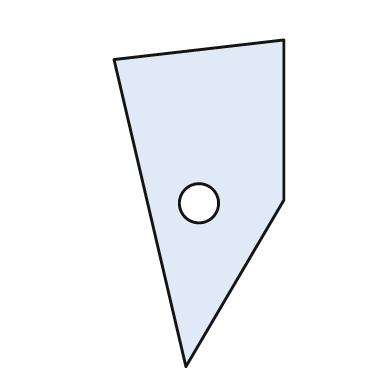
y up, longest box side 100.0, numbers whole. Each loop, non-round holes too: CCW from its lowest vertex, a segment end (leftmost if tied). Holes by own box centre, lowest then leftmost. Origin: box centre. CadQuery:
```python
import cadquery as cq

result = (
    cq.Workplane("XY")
    .moveTo(-4.0, -50.0)
    .lineTo(26.0, 1.0)
    .lineTo(26.0, 50.0)
    .lineTo(-26.0, 44.0)
    .close()
    .moveTo(0.0, 0.0)
    .circle(6.0)
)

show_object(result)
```